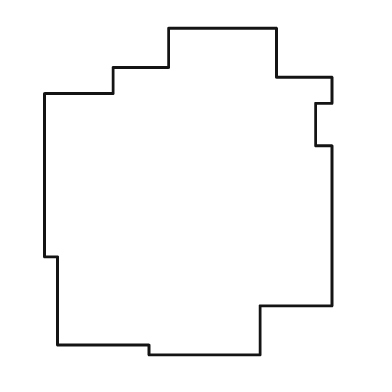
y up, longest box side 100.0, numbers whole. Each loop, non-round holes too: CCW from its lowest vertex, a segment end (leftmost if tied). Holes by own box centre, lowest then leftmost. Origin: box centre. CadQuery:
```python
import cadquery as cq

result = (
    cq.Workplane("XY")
    .moveTo(-12.0, -50.0)
    .lineTo(22.0, -50.0)
    .lineTo(22.0, -35.0)
    .lineTo(44.0, -35.0)
    .lineTo(44.0, 14.0)
    .lineTo(39.0, 14.0)
    .lineTo(39.0, 27.0)
    .lineTo(44.0, 27.0)
    .lineTo(44.0, 35.0)
    .lineTo(27.0, 35.0)
    .lineTo(27.0, 50.0)
    .lineTo(-6.0, 50.0)
    .lineTo(-6.0, 38.0)
    .lineTo(-23.0, 38.0)
    .lineTo(-23.0, 30.0)
    .lineTo(-44.0, 30.0)
    .lineTo(-44.0, -20.0)
    .lineTo(-40.0, -20.0)
    .lineTo(-40.0, -47.0)
    .lineTo(-12.0, -47.0)
    .close()
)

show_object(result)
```